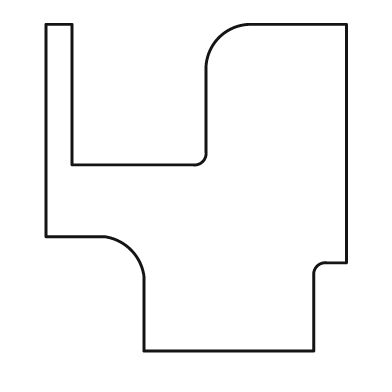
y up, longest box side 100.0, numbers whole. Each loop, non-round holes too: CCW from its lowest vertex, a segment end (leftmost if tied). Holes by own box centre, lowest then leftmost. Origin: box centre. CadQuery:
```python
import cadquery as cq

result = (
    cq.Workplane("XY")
    .moveTo(-16.0, -50.0)
    .lineTo(36.0, -50.0)
    .lineTo(36.0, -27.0)
    .threePointArc((37.0, -24.0), (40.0, -23.0))
    .lineTo(46.0, -23.0)
    .lineTo(46.0, 50.0)
    .lineTo(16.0, 50.0)
    .threePointArc((7.0, 46.0), (3.0, 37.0))
    .lineTo(3.0, 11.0)
    .threePointArc((2.0, 8.0), (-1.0, 7.0))
    .lineTo(-38.0, 7.0)
    .lineTo(-38.0, 50.0)
    .lineTo(-46.0, 50.0)
    .lineTo(-46.0, -15.0)
    .lineTo(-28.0, -15.0)
    .threePointArc((-20.0, -19.0), (-16.0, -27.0))
    .close()
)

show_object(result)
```